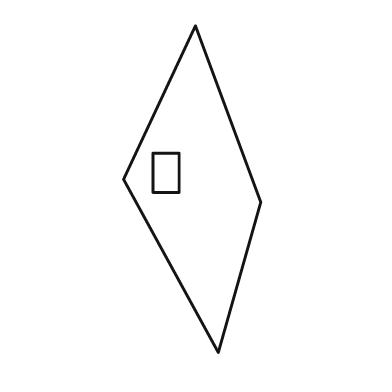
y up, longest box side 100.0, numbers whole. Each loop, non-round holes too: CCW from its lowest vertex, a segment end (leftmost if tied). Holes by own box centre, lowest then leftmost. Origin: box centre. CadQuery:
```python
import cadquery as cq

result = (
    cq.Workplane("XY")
    .moveTo(8.0, -50.0)
    .lineTo(21.0, -4.0)
    .lineTo(1.0, 50.0)
    .lineTo(-21.0, 3.0)
    .close()
    .moveTo(-12.0, -1.0)
    .lineTo(-4.0, -1.0)
    .lineTo(-4.0, 11.0)
    .lineTo(-12.0, 11.0)
    .close()
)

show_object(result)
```